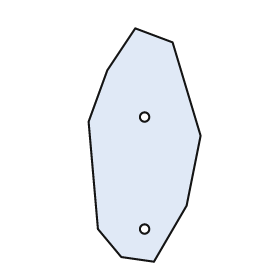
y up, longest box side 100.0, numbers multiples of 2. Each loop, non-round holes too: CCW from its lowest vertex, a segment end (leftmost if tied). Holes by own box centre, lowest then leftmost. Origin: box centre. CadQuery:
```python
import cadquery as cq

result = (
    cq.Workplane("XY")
    .moveTo(4.0, -50.0)
    .lineTo(18.0, -26.0)
    .lineTo(24.0, 4.0)
    .lineTo(12.0, 44.0)
    .lineTo(-4.0, 50.0)
    .lineTo(-16.0, 32.0)
    .lineTo(-24.0, 10.0)
    .lineTo(-20.0, -36.0)
    .lineTo(-10.0, -48.0)
    .close()
    .moveTo(0.0, -36.0)
    .circle(2.0)
    .moveTo(0.0, 12.0)
    .circle(2.0)
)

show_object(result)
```